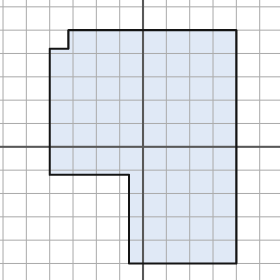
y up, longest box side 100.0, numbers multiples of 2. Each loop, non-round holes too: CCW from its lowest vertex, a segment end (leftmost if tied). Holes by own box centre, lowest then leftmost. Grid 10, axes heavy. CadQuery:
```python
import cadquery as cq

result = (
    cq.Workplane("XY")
    .moveTo(-6.0, -50.0)
    .lineTo(40.0, -50.0)
    .lineTo(40.0, 50.0)
    .lineTo(-32.0, 50.0)
    .lineTo(-32.0, 42.0)
    .lineTo(-40.0, 42.0)
    .lineTo(-40.0, -12.0)
    .lineTo(-6.0, -12.0)
    .close()
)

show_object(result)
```